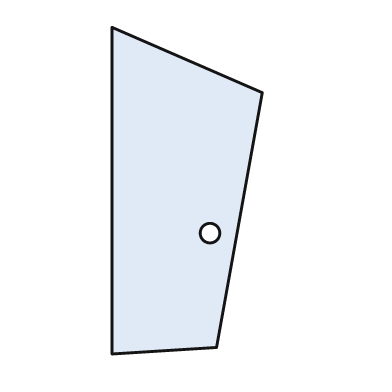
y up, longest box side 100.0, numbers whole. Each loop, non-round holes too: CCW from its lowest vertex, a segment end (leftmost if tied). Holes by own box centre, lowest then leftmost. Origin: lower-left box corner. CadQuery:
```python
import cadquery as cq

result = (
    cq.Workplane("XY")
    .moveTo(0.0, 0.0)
    .lineTo(32.0, 2.0)
    .lineTo(46.0, 80.0)
    .lineTo(0.0, 100.0)
    .close()
    .moveTo(30.0, 37.0)
    .circle(3.0)
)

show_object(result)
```